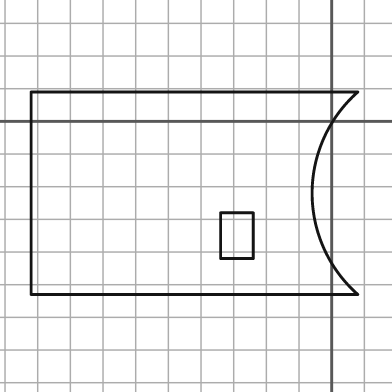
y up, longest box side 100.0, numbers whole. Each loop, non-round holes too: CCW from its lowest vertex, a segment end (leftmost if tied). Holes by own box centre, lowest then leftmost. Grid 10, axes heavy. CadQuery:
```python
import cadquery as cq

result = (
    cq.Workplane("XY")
    .moveTo(-92.0, -53.0)
    .lineTo(8.0, -53.0)
    .threePointArc((-6.0, -22.0), (8.0, 9.0))
    .lineTo(-92.0, 9.0)
    .close()
    .moveTo(-34.0, -42.0)
    .lineTo(-24.0, -42.0)
    .lineTo(-24.0, -28.0)
    .lineTo(-34.0, -28.0)
    .close()
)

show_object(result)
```